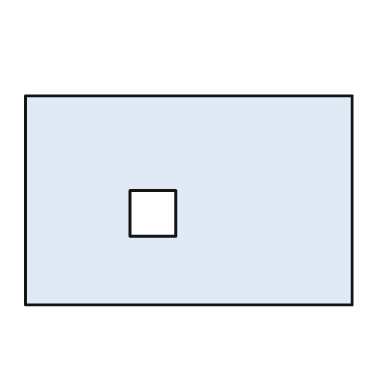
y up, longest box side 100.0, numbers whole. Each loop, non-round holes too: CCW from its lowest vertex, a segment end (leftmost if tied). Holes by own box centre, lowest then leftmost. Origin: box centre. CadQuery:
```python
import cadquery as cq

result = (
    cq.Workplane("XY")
    .moveTo(-50.0, -32.0)
    .lineTo(50.0, -32.0)
    .lineTo(50.0, 32.0)
    .lineTo(-50.0, 32.0)
    .close()
    .moveTo(-18.0, -11.0)
    .lineTo(-4.0, -11.0)
    .lineTo(-4.0, 3.0)
    .lineTo(-18.0, 3.0)
    .close()
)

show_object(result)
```